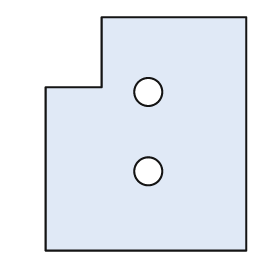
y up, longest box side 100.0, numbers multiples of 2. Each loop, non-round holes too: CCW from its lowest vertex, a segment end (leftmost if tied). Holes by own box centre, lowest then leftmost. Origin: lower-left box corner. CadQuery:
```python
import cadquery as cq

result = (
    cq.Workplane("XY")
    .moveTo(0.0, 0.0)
    .lineTo(86.0, 0.0)
    .lineTo(86.0, 100.0)
    .lineTo(24.0, 100.0)
    .lineTo(24.0, 70.0)
    .lineTo(0.0, 70.0)
    .close()
    .moveTo(44.0, 34.0)
    .circle(6.0)
    .moveTo(44.0, 68.0)
    .circle(6.0)
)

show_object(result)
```